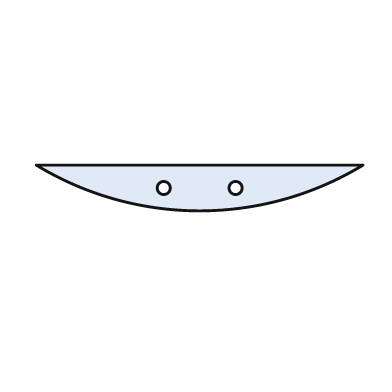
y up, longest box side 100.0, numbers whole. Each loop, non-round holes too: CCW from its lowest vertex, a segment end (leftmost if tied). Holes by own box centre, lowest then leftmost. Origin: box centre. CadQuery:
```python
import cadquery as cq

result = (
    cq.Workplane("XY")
    .moveTo(-50.0, 7.0)
    .threePointArc((0.0, -7.0), (50.0, 7.0))
    .close()
    .moveTo(-11.0, 0.0)
    .circle(2.0)
    .moveTo(11.0, 0.0)
    .circle(2.0)
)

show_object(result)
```